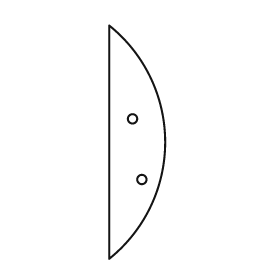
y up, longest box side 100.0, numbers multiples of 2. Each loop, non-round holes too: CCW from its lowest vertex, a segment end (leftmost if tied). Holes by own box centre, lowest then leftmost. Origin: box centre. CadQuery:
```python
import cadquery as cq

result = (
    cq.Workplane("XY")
    .moveTo(-12.0, -50.0)
    .threePointArc((12.0, 0.0), (-12.0, 50.0))
    .close()
    .moveTo(2.0, -16.0)
    .circle(2.0)
    .moveTo(-2.0, 10.0)
    .circle(2.0)
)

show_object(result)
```